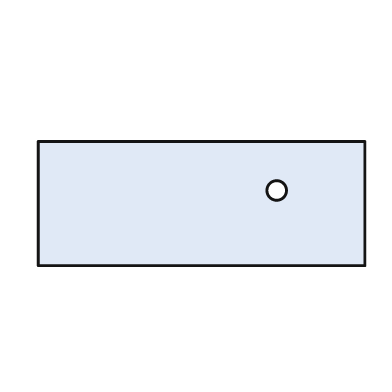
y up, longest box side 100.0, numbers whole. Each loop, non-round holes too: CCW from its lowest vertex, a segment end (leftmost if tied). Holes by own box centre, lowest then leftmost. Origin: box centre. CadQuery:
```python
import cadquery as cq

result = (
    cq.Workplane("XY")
    .moveTo(-50.0, -19.0)
    .lineTo(50.0, -19.0)
    .lineTo(50.0, 19.0)
    .lineTo(-50.0, 19.0)
    .close()
    .moveTo(23.0, 4.0)
    .circle(3.0)
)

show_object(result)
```